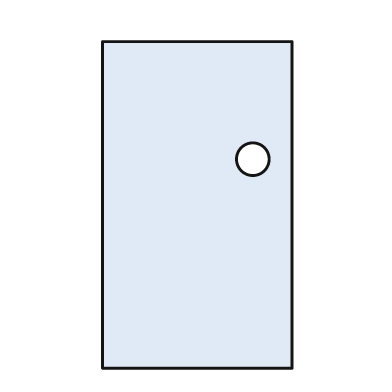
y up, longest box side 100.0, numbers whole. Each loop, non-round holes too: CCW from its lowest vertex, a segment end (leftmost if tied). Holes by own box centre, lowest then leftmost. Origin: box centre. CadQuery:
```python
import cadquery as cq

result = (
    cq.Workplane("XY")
    .moveTo(-29.0, -50.0)
    .lineTo(29.0, -50.0)
    .lineTo(29.0, 50.0)
    .lineTo(-29.0, 50.0)
    .close()
    .moveTo(17.0, 14.0)
    .circle(5.0)
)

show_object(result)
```